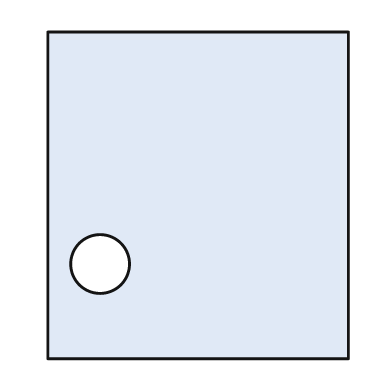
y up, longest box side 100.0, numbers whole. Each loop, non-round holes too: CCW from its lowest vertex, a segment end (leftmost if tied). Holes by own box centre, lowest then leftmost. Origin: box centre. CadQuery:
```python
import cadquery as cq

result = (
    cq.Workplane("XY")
    .moveTo(-46.0, -50.0)
    .lineTo(46.0, -50.0)
    .lineTo(46.0, 50.0)
    .lineTo(-46.0, 50.0)
    .close()
    .moveTo(-30.0, -21.0)
    .circle(9.0)
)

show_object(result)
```